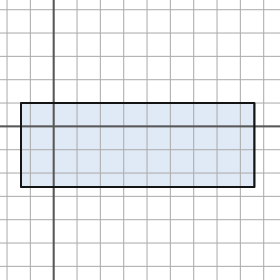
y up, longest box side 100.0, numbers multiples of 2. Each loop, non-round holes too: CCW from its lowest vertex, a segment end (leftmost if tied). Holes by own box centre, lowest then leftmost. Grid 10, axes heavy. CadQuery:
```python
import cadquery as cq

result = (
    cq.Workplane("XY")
    .moveTo(-14.0, -26.0)
    .lineTo(86.0, -26.0)
    .lineTo(86.0, 10.0)
    .lineTo(-14.0, 10.0)
    .close()
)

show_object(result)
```